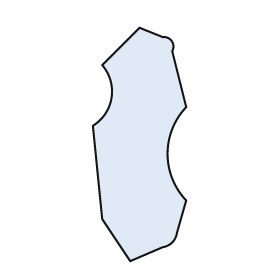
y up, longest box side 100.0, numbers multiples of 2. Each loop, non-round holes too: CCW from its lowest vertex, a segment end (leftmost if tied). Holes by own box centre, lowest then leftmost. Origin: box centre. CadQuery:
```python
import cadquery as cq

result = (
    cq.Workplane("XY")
    .moveTo(-4.0, -50.0)
    .lineTo(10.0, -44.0)
    .threePointArc((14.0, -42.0), (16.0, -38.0))
    .lineTo(20.0, -24.0)
    .threePointArc((12.0, -4.0), (20.0, 16.0))
    .lineTo(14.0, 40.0)
    .threePointArc((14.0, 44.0), (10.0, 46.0))
    .lineTo(0.0, 50.0)
    .lineTo(-16.0, 34.0)
    .threePointArc((-12.0, 20.0), (-20.0, 8.0))
    .lineTo(-16.0, -32.0)
    .close()
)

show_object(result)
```